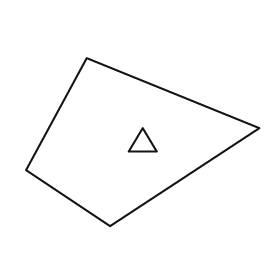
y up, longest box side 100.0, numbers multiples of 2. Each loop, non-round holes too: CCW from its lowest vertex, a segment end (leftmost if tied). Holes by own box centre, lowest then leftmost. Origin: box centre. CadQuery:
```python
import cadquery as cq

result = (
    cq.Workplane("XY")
    .moveTo(-14.0, -36.0)
    .lineTo(50.0, 6.0)
    .lineTo(-24.0, 36.0)
    .lineTo(-50.0, -12.0)
    .close()
    .moveTo(-6.0, -4.0)
    .lineTo(6.0, -4.0)
    .lineTo(0.0, 6.0)
    .close()
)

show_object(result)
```